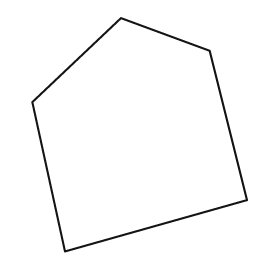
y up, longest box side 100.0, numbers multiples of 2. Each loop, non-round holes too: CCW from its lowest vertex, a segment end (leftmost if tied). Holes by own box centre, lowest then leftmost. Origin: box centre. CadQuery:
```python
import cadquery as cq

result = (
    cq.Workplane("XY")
    .moveTo(-32.0, -50.0)
    .lineTo(46.0, -28.0)
    .lineTo(30.0, 36.0)
    .lineTo(-8.0, 50.0)
    .lineTo(-46.0, 14.0)
    .close()
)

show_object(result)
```